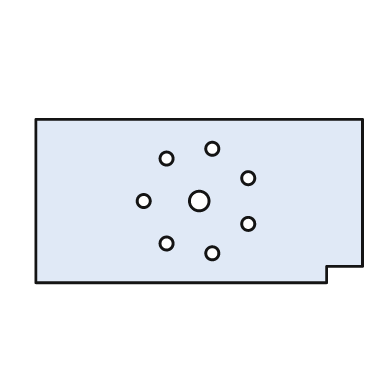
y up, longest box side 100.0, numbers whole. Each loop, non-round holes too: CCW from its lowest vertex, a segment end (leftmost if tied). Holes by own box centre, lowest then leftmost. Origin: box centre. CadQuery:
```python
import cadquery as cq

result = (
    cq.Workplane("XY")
    .moveTo(-50.0, -25.0)
    .lineTo(39.0, -25.0)
    .lineTo(39.0, -20.0)
    .lineTo(50.0, -20.0)
    .lineTo(50.0, 25.0)
    .lineTo(-50.0, 25.0)
    .close()
    .moveTo(4.0, -16.0)
    .circle(2.0)
    .moveTo(-10.0, -13.0)
    .circle(2.0)
    .moveTo(15.0, -7.0)
    .circle(2.0)
    .moveTo(-17.0, 0.0)
    .circle(2.0)
    .moveTo(0.0, 0.0)
    .circle(3.0)
    .moveTo(15.0, 7.0)
    .circle(2.0)
    .moveTo(-10.0, 13.0)
    .circle(2.0)
    .moveTo(4.0, 16.0)
    .circle(2.0)
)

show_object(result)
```